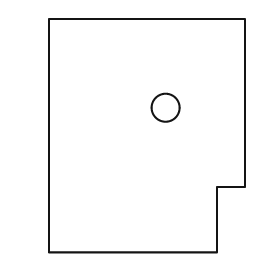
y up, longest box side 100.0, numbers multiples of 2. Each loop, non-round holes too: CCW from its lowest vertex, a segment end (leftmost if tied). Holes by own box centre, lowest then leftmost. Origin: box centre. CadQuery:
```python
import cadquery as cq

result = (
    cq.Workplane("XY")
    .moveTo(-42.0, -50.0)
    .lineTo(30.0, -50.0)
    .lineTo(30.0, -22.0)
    .lineTo(42.0, -22.0)
    .lineTo(42.0, 50.0)
    .lineTo(-42.0, 50.0)
    .close()
    .moveTo(8.0, 12.0)
    .circle(6.0)
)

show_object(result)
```